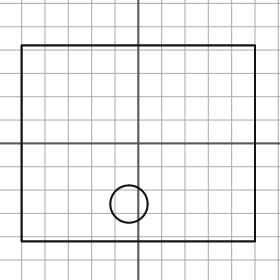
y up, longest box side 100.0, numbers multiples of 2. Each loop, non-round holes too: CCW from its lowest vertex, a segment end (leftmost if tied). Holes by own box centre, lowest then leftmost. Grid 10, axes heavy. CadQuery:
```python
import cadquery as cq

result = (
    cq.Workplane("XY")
    .moveTo(-50.0, -42.0)
    .lineTo(50.0, -42.0)
    .lineTo(50.0, 42.0)
    .lineTo(-50.0, 42.0)
    .close()
    .moveTo(-4.0, -26.0)
    .circle(8.0)
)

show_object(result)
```